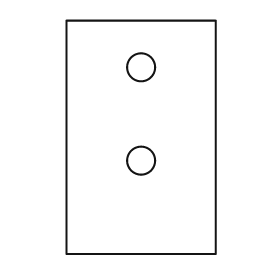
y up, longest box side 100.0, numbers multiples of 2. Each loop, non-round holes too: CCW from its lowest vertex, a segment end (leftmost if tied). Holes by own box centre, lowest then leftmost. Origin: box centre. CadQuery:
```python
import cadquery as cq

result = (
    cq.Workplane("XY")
    .moveTo(-32.0, -50.0)
    .lineTo(32.0, -50.0)
    .lineTo(32.0, 50.0)
    .lineTo(-32.0, 50.0)
    .close()
    .moveTo(0.0, -10.0)
    .circle(6.0)
    .moveTo(0.0, 30.0)
    .circle(6.0)
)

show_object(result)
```